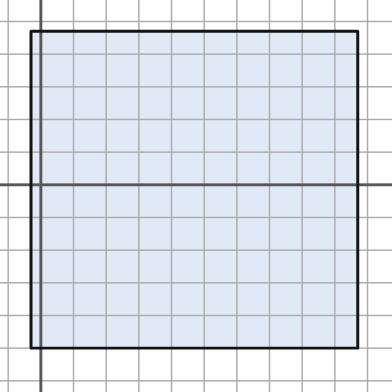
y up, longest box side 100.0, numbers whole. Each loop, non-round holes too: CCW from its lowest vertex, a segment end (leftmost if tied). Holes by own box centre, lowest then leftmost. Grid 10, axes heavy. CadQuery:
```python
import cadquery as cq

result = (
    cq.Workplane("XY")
    .moveTo(-3.0, -50.0)
    .lineTo(97.0, -50.0)
    .lineTo(97.0, 47.0)
    .lineTo(-3.0, 47.0)
    .close()
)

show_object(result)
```